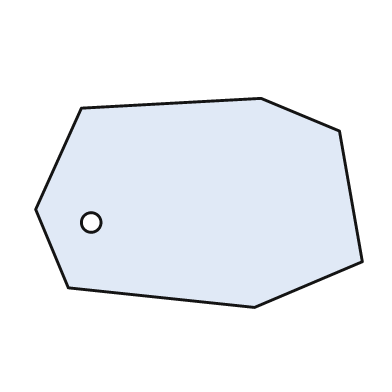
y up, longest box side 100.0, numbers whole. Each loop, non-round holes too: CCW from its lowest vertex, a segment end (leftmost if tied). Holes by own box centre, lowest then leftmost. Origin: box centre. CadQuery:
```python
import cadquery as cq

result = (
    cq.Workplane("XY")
    .moveTo(17.0, -32.0)
    .lineTo(50.0, -18.0)
    .lineTo(43.0, 22.0)
    .lineTo(19.0, 32.0)
    .lineTo(-36.0, 29.0)
    .lineTo(-50.0, -2.0)
    .lineTo(-40.0, -26.0)
    .close()
    .moveTo(-33.0, -6.0)
    .circle(3.0)
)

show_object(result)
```